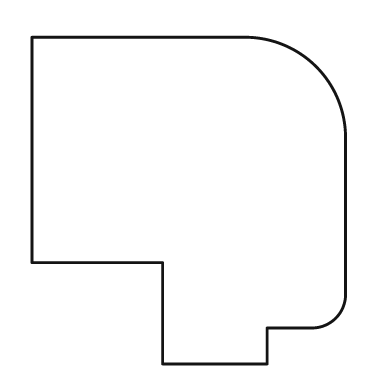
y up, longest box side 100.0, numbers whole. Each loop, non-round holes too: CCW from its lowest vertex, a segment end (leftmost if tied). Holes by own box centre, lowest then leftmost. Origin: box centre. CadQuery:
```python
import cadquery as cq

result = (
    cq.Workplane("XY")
    .moveTo(-8.0, -50.0)
    .lineTo(24.0, -50.0)
    .lineTo(24.0, -39.0)
    .lineTo(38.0, -39.0)
    .threePointArc((45.0, -36.0), (48.0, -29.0))
    .lineTo(48.0, 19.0)
    .threePointArc((39.0, 41.0), (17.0, 50.0))
    .lineTo(-48.0, 50.0)
    .lineTo(-48.0, -19.0)
    .lineTo(-8.0, -19.0)
    .close()
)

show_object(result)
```